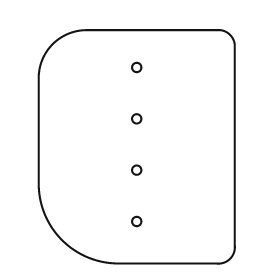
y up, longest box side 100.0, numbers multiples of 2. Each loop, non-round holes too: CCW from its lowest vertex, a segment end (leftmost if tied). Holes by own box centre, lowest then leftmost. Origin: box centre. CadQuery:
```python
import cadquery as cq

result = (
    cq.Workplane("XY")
    .moveTo(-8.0, -50.0)
    .lineTo(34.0, -50.0)
    .threePointArc((40.0, -48.0), (42.0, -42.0))
    .lineTo(42.0, 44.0)
    .threePointArc((40.0, 48.0), (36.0, 50.0))
    .lineTo(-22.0, 50.0)
    .threePointArc((-36.0, 44.0), (-42.0, 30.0))
    .lineTo(-42.0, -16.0)
    .threePointArc((-32.0, -40.0), (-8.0, -50.0))
    .close()
    .moveTo(0.0, -32.0)
    .circle(2.0)
    .moveTo(0.0, -10.0)
    .circle(2.0)
    .moveTo(0.0, 12.0)
    .circle(2.0)
    .moveTo(0.0, 34.0)
    .circle(2.0)
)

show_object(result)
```